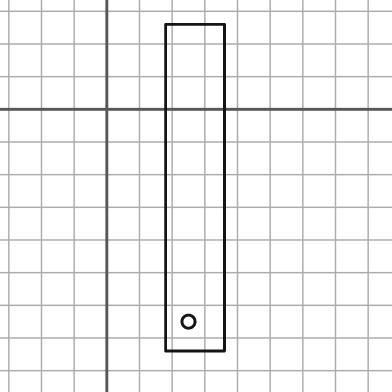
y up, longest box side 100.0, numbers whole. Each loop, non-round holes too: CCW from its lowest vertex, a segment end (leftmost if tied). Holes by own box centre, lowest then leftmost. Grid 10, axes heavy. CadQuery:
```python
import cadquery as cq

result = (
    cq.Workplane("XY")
    .moveTo(18.0, -74.0)
    .lineTo(36.0, -74.0)
    .lineTo(36.0, 26.0)
    .lineTo(18.0, 26.0)
    .close()
    .moveTo(25.0, -65.0)
    .circle(2.0)
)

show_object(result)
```